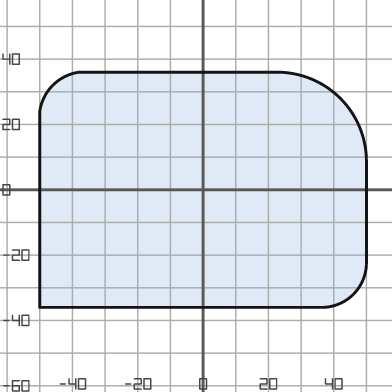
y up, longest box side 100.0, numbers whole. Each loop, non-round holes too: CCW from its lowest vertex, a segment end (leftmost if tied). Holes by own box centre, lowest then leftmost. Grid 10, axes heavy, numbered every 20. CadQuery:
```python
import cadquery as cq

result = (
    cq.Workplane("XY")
    .moveTo(-50.0, -36.0)
    .lineTo(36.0, -36.0)
    .threePointArc((46.0, -32.0), (50.0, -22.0))
    .lineTo(50.0, 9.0)
    .threePointArc((42.0, 28.0), (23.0, 36.0))
    .lineTo(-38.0, 36.0)
    .threePointArc((-46.0, 32.0), (-50.0, 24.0))
    .close()
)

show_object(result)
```